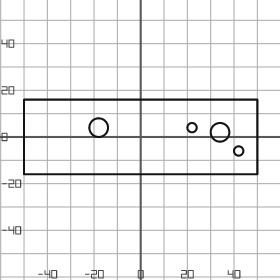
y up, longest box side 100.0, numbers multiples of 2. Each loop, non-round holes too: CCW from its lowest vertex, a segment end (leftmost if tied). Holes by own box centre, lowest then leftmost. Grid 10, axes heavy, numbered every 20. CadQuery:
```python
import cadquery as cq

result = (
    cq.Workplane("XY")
    .moveTo(-50.0, -16.0)
    .lineTo(50.0, -16.0)
    .lineTo(50.0, 16.0)
    .lineTo(-50.0, 16.0)
    .close()
    .moveTo(42.0, -6.0)
    .circle(2.0)
    .moveTo(34.0, 2.0)
    .circle(4.0)
    .moveTo(-18.0, 4.0)
    .circle(4.0)
    .moveTo(22.0, 4.0)
    .circle(2.0)
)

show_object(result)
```